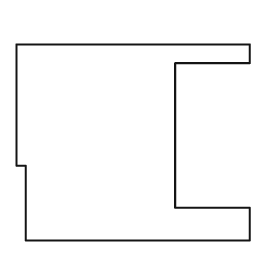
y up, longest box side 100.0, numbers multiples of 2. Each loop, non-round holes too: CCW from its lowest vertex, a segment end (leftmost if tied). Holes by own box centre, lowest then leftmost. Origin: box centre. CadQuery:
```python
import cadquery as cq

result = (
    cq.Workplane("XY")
    .moveTo(-46.0, -42.0)
    .lineTo(50.0, -42.0)
    .lineTo(50.0, -28.0)
    .lineTo(18.0, -28.0)
    .lineTo(18.0, 34.0)
    .lineTo(50.0, 34.0)
    .lineTo(50.0, 42.0)
    .lineTo(-50.0, 42.0)
    .lineTo(-50.0, -10.0)
    .lineTo(-46.0, -10.0)
    .close()
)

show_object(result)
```